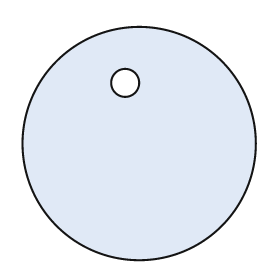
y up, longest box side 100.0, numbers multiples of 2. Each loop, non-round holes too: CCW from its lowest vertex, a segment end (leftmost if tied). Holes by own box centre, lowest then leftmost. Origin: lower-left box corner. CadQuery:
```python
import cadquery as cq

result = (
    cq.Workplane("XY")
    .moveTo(50.0, 50.0)
    .circle(50.0)
    .moveTo(44.0, 76.0)
    .circle(6.0)
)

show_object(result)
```